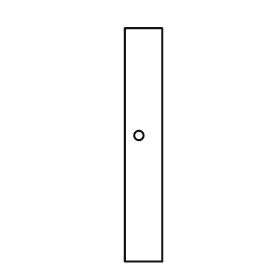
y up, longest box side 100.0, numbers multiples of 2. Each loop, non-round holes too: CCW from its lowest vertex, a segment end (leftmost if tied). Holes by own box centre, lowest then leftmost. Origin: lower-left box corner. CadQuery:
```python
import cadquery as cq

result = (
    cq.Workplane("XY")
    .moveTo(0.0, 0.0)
    .lineTo(16.0, 0.0)
    .lineTo(16.0, 100.0)
    .lineTo(0.0, 100.0)
    .close()
    .moveTo(6.0, 54.0)
    .circle(2.0)
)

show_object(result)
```